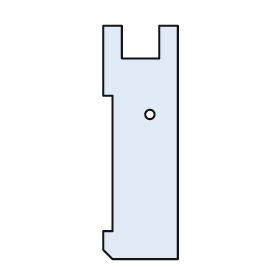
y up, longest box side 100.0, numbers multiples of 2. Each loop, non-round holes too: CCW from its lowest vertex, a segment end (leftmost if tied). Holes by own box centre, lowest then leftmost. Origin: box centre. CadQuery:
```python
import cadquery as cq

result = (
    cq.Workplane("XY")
    .moveTo(-12.0, -50.0)
    .lineTo(16.0, -50.0)
    .lineTo(16.0, 50.0)
    .lineTo(8.0, 50.0)
    .lineTo(8.0, 36.0)
    .lineTo(-8.0, 36.0)
    .lineTo(-8.0, 50.0)
    .lineTo(-16.0, 50.0)
    .lineTo(-16.0, 20.0)
    .lineTo(-12.0, 20.0)
    .lineTo(-12.0, -38.0)
    .lineTo(-16.0, -38.0)
    .lineTo(-16.0, -46.0)
    .close()
    .moveTo(4.0, 12.0)
    .circle(2.0)
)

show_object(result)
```